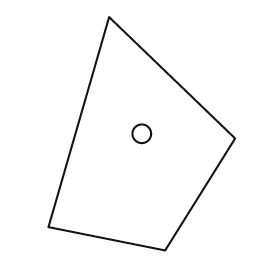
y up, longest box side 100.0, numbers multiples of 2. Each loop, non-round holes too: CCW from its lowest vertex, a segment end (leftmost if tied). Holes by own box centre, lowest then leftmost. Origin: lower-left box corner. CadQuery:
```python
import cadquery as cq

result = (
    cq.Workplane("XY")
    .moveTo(50.0, 0.0)
    .lineTo(80.0, 48.0)
    .lineTo(26.0, 100.0)
    .lineTo(0.0, 10.0)
    .close()
    .moveTo(40.0, 50.0)
    .circle(4.0)
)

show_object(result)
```